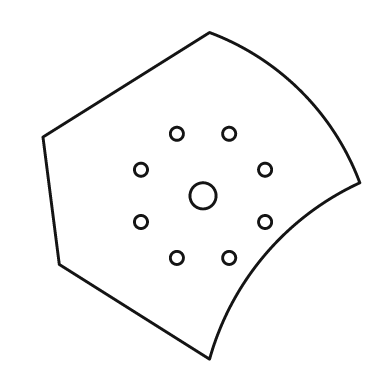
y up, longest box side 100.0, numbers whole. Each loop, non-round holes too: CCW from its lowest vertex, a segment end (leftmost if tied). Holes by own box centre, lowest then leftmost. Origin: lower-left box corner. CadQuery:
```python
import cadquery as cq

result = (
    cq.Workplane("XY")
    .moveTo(51.0, 0.0)
    .threePointArc((68.0, 32.0), (97.0, 54.0))
    .threePointArc((79.0, 82.0), (51.0, 100.0))
    .lineTo(0.0, 68.0)
    .lineTo(5.0, 29.0)
    .close()
    .moveTo(41.0, 31.0)
    .circle(2.0)
    .moveTo(57.0, 31.0)
    .circle(2.0)
    .moveTo(30.0, 42.0)
    .circle(2.0)
    .moveTo(68.0, 42.0)
    .circle(2.0)
    .moveTo(49.0, 50.0)
    .circle(4.0)
    .moveTo(30.0, 58.0)
    .circle(2.0)
    .moveTo(68.0, 58.0)
    .circle(2.0)
    .moveTo(41.0, 69.0)
    .circle(2.0)
    .moveTo(57.0, 69.0)
    .circle(2.0)
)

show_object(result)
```